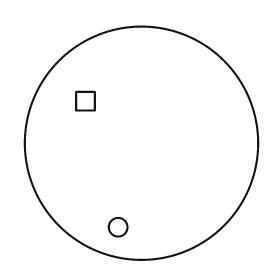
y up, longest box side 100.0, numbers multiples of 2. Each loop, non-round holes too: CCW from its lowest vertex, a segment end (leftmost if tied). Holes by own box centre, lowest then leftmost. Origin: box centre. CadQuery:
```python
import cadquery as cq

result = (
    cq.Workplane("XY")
    .moveTo(0.0, 0.0)
    .circle(50.0)
    .moveTo(-10.0, -36.0)
    .circle(4.0)
    .moveTo(-28.0, 14.0)
    .lineTo(-20.0, 14.0)
    .lineTo(-20.0, 22.0)
    .lineTo(-28.0, 22.0)
    .close()
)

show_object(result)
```